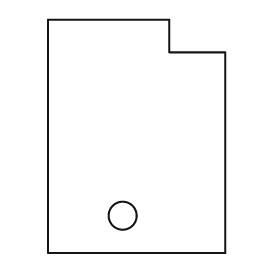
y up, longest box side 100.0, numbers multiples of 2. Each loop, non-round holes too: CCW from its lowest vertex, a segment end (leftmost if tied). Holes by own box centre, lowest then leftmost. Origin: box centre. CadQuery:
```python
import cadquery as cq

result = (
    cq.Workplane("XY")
    .moveTo(-38.0, -50.0)
    .lineTo(38.0, -50.0)
    .lineTo(38.0, 36.0)
    .lineTo(14.0, 36.0)
    .lineTo(14.0, 50.0)
    .lineTo(-38.0, 50.0)
    .close()
    .moveTo(-6.0, -34.0)
    .circle(6.0)
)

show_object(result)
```